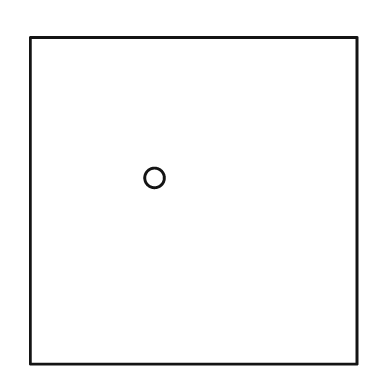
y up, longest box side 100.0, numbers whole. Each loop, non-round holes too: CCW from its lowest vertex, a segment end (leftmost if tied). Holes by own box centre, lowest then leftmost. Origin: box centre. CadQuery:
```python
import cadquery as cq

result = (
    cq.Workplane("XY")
    .moveTo(-50.0, -50.0)
    .lineTo(50.0, -50.0)
    .lineTo(50.0, 50.0)
    .lineTo(-50.0, 50.0)
    .close()
    .moveTo(-12.0, 7.0)
    .circle(3.0)
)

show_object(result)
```